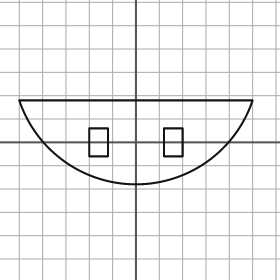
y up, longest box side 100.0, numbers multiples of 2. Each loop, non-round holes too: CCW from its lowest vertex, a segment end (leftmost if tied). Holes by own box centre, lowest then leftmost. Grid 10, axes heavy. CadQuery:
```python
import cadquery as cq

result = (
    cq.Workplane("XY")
    .moveTo(-50.0, 18.0)
    .threePointArc((0.0, -18.0), (50.0, 18.0))
    .close()
    .moveTo(-20.0, -6.0)
    .lineTo(-12.0, -6.0)
    .lineTo(-12.0, 6.0)
    .lineTo(-20.0, 6.0)
    .close()
    .moveTo(12.0, -6.0)
    .lineTo(20.0, -6.0)
    .lineTo(20.0, 6.0)
    .lineTo(12.0, 6.0)
    .close()
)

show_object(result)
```